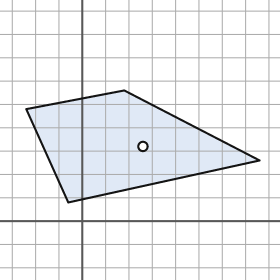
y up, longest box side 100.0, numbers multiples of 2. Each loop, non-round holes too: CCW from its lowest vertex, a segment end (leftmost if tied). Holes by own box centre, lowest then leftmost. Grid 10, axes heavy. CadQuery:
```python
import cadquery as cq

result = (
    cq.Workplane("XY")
    .moveTo(-6.0, 8.0)
    .lineTo(76.0, 26.0)
    .lineTo(18.0, 56.0)
    .lineTo(-24.0, 48.0)
    .close()
    .moveTo(26.0, 32.0)
    .circle(2.0)
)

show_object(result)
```